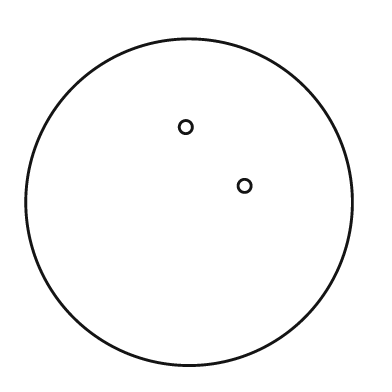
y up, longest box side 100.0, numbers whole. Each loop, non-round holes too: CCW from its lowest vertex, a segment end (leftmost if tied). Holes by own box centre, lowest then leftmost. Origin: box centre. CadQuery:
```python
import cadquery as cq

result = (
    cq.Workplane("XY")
    .moveTo(0.0, 0.0)
    .circle(50.0)
    .moveTo(17.0, 5.0)
    .circle(2.0)
    .moveTo(-1.0, 23.0)
    .circle(2.0)
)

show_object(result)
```